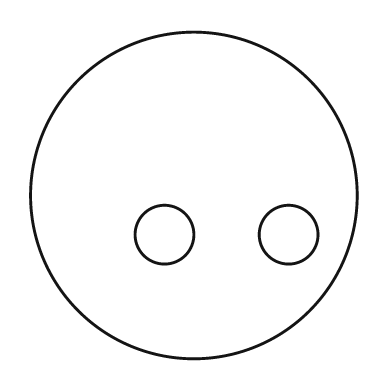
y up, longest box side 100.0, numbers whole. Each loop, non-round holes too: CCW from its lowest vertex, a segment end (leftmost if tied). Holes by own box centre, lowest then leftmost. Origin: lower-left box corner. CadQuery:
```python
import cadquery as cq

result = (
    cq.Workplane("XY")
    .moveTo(50.0, 50.0)
    .circle(50.0)
    .moveTo(41.0, 38.0)
    .circle(9.0)
    .moveTo(79.0, 38.0)
    .circle(9.0)
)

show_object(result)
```